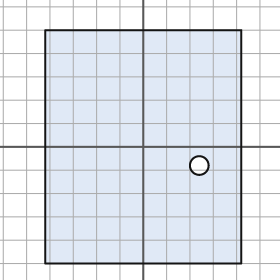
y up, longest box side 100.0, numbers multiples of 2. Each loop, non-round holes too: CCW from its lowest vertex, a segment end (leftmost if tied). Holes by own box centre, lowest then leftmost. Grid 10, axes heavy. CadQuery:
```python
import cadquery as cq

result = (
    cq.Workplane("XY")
    .moveTo(-42.0, -50.0)
    .lineTo(42.0, -50.0)
    .lineTo(42.0, 50.0)
    .lineTo(-42.0, 50.0)
    .close()
    .moveTo(24.0, -8.0)
    .circle(4.0)
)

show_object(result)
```